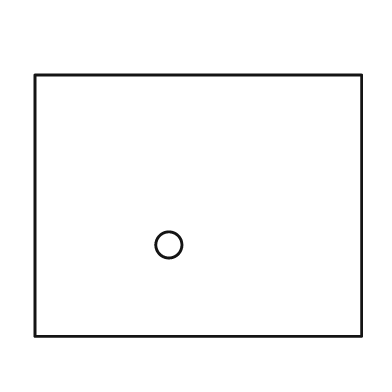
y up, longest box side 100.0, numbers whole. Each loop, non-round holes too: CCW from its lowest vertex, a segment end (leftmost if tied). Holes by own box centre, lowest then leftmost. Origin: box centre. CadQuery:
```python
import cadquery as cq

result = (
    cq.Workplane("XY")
    .moveTo(-50.0, -40.0)
    .lineTo(50.0, -40.0)
    .lineTo(50.0, 40.0)
    .lineTo(-50.0, 40.0)
    .close()
    .moveTo(-9.0, -12.0)
    .circle(4.0)
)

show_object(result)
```